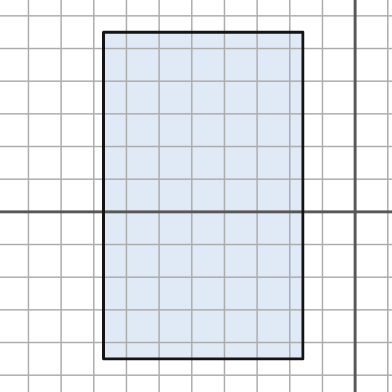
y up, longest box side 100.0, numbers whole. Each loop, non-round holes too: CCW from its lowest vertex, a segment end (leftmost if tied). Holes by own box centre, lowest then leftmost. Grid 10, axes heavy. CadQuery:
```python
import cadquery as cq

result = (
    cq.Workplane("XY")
    .moveTo(-77.0, -45.0)
    .lineTo(-16.0, -45.0)
    .lineTo(-16.0, 55.0)
    .lineTo(-77.0, 55.0)
    .close()
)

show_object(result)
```